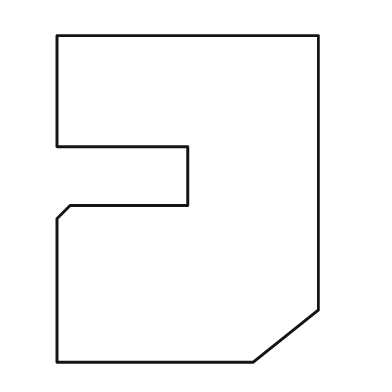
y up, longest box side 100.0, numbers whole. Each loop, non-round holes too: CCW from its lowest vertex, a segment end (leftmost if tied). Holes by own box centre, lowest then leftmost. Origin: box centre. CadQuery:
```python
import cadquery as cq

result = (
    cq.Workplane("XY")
    .moveTo(-40.0, -50.0)
    .lineTo(20.0, -50.0)
    .lineTo(40.0, -34.0)
    .lineTo(40.0, 50.0)
    .lineTo(-40.0, 50.0)
    .lineTo(-40.0, 16.0)
    .lineTo(0.0, 16.0)
    .lineTo(0.0, -2.0)
    .lineTo(-36.0, -2.0)
    .lineTo(-40.0, -6.0)
    .close()
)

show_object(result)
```